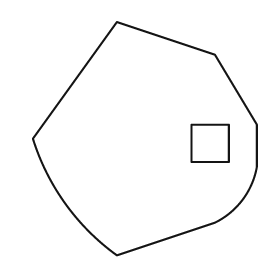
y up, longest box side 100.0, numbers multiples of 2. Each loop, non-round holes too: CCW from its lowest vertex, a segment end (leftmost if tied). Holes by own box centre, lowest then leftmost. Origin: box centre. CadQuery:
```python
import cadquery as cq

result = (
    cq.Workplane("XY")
    .moveTo(-12.0, -50.0)
    .lineTo(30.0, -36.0)
    .threePointArc((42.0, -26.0), (48.0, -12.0))
    .lineTo(48.0, 6.0)
    .lineTo(30.0, 36.0)
    .lineTo(-12.0, 50.0)
    .lineTo(-48.0, 0.0)
    .threePointArc((-34.0, -28.0), (-12.0, -50.0))
    .close()
    .moveTo(20.0, -10.0)
    .lineTo(36.0, -10.0)
    .lineTo(36.0, 6.0)
    .lineTo(20.0, 6.0)
    .close()
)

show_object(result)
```